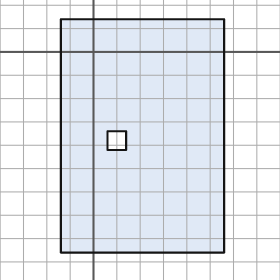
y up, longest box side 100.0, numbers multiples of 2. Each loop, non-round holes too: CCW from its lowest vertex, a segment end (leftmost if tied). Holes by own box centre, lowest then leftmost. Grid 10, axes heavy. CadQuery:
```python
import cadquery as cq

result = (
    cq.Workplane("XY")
    .moveTo(-14.0, -86.0)
    .lineTo(56.0, -86.0)
    .lineTo(56.0, 14.0)
    .lineTo(-14.0, 14.0)
    .close()
    .moveTo(6.0, -42.0)
    .lineTo(14.0, -42.0)
    .lineTo(14.0, -34.0)
    .lineTo(6.0, -34.0)
    .close()
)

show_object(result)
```